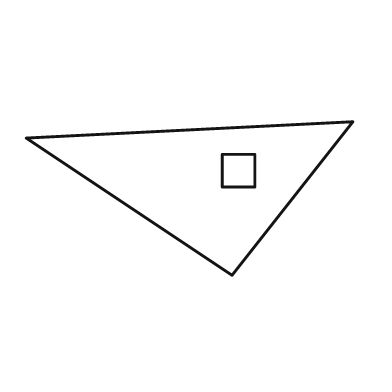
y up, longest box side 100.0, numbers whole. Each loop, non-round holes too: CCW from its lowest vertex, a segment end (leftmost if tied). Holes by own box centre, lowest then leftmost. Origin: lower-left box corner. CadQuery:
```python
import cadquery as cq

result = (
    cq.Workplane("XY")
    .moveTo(63.0, 0.0)
    .lineTo(100.0, 47.0)
    .lineTo(0.0, 42.0)
    .close()
    .moveTo(60.0, 27.0)
    .lineTo(70.0, 27.0)
    .lineTo(70.0, 37.0)
    .lineTo(60.0, 37.0)
    .close()
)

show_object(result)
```